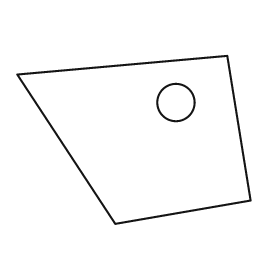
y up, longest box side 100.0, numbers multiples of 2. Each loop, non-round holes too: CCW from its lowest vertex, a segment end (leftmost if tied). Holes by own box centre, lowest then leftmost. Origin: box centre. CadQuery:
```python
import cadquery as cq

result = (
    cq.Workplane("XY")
    .moveTo(-8.0, -36.0)
    .lineTo(50.0, -26.0)
    .lineTo(40.0, 36.0)
    .lineTo(-50.0, 28.0)
    .close()
    .moveTo(18.0, 16.0)
    .circle(8.0)
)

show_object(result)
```